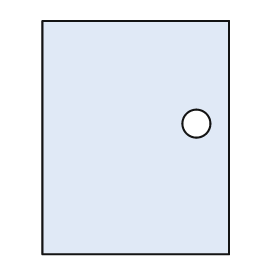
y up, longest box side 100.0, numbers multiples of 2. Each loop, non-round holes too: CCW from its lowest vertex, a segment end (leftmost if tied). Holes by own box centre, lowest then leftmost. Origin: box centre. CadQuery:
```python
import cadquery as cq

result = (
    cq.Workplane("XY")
    .moveTo(-40.0, -50.0)
    .lineTo(40.0, -50.0)
    .lineTo(40.0, 50.0)
    .lineTo(-40.0, 50.0)
    .close()
    .moveTo(26.0, 6.0)
    .circle(6.0)
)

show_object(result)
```